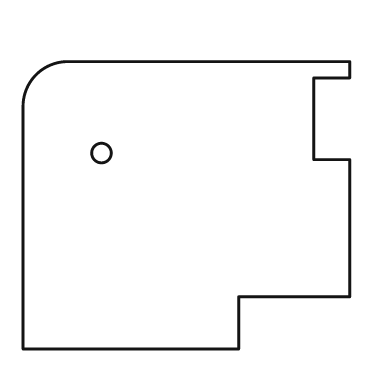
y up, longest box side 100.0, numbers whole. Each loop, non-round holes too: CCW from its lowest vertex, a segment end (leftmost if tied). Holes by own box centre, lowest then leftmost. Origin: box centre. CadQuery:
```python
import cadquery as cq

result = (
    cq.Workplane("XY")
    .moveTo(-50.0, -44.0)
    .lineTo(16.0, -44.0)
    .lineTo(16.0, -28.0)
    .lineTo(50.0, -28.0)
    .lineTo(50.0, 14.0)
    .lineTo(39.0, 14.0)
    .lineTo(39.0, 39.0)
    .lineTo(50.0, 39.0)
    .lineTo(50.0, 44.0)
    .lineTo(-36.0, 44.0)
    .threePointArc((-46.0, 40.0), (-50.0, 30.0))
    .close()
    .moveTo(-26.0, 16.0)
    .circle(3.0)
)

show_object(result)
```